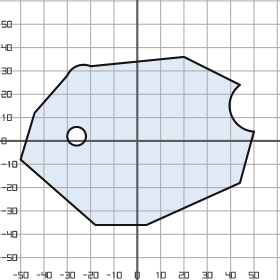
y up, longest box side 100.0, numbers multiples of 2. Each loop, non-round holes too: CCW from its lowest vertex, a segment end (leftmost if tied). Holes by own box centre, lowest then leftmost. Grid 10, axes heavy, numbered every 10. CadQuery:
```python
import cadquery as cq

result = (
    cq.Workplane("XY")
    .moveTo(-18.0, -36.0)
    .lineTo(4.0, -36.0)
    .lineTo(44.0, -18.0)
    .lineTo(50.0, 4.0)
    .threePointArc((40.0, 12.0), (44.0, 24.0))
    .lineTo(20.0, 36.0)
    .lineTo(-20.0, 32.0)
    .threePointArc((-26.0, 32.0), (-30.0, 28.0))
    .lineTo(-44.0, 12.0)
    .lineTo(-50.0, -8.0)
    .close()
    .moveTo(-26.0, 2.0)
    .circle(4.0)
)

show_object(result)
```